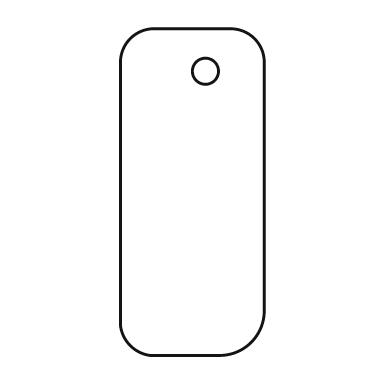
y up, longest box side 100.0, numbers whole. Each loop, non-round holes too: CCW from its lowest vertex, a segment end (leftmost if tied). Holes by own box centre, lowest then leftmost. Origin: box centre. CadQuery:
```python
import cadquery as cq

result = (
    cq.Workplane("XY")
    .moveTo(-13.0, -50.0)
    .lineTo(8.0, -50.0)
    .threePointArc((18.0, -46.0), (22.0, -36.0))
    .lineTo(22.0, 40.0)
    .threePointArc((19.0, 47.0), (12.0, 50.0))
    .lineTo(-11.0, 50.0)
    .threePointArc((-19.0, 47.0), (-22.0, 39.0))
    .lineTo(-22.0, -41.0)
    .threePointArc((-19.0, -47.0), (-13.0, -50.0))
    .close()
    .moveTo(4.0, 37.0)
    .circle(4.0)
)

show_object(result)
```